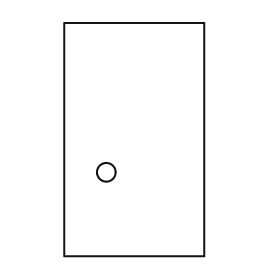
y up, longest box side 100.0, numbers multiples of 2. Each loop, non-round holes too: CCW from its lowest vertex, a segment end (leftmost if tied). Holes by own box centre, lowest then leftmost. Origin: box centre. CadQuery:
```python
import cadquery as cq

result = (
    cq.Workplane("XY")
    .moveTo(-30.0, -50.0)
    .lineTo(30.0, -50.0)
    .lineTo(30.0, 50.0)
    .lineTo(-30.0, 50.0)
    .close()
    .moveTo(-12.0, -14.0)
    .circle(4.0)
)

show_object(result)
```